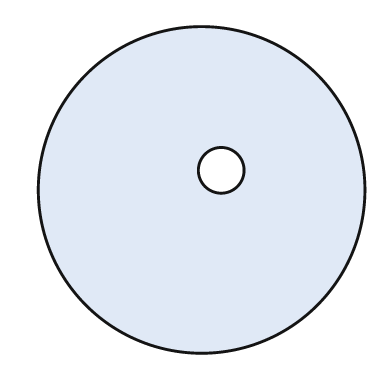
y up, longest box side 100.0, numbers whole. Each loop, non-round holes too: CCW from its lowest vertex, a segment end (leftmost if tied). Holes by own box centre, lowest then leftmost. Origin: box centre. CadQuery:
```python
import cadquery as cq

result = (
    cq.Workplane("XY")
    .moveTo(0.0, 0.0)
    .circle(50.0)
    .moveTo(6.0, 6.0)
    .circle(7.0)
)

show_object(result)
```